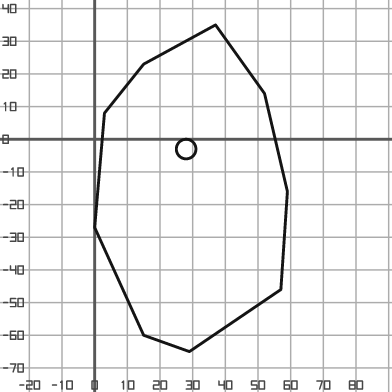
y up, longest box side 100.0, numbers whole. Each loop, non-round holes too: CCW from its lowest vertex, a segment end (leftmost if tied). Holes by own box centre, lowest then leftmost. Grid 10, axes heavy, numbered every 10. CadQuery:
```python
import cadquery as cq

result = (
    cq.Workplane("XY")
    .moveTo(29.0, -65.0)
    .lineTo(57.0, -46.0)
    .lineTo(59.0, -16.0)
    .lineTo(52.0, 14.0)
    .lineTo(37.0, 35.0)
    .lineTo(15.0, 23.0)
    .lineTo(3.0, 8.0)
    .lineTo(0.0, -27.0)
    .lineTo(15.0, -60.0)
    .close()
    .moveTo(28.0, -3.0)
    .circle(3.0)
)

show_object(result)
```